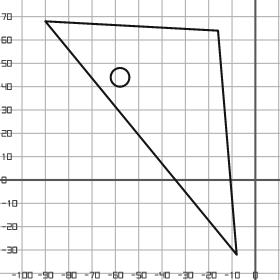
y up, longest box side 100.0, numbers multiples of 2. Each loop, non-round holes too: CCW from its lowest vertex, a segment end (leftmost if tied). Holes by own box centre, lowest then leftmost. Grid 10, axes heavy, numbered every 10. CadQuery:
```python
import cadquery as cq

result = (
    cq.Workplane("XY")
    .moveTo(-8.0, -32.0)
    .lineTo(-16.0, 64.0)
    .lineTo(-90.0, 68.0)
    .close()
    .moveTo(-58.0, 44.0)
    .circle(4.0)
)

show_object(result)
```